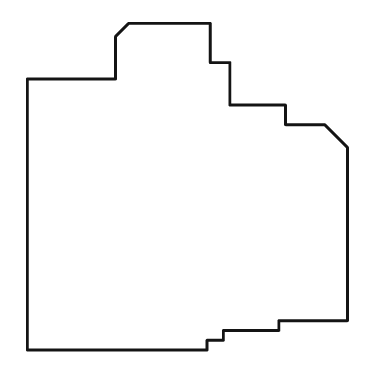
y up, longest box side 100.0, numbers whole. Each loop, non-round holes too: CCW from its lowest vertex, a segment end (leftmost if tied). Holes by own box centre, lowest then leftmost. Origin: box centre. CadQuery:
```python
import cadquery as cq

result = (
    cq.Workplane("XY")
    .moveTo(-49.0, -50.0)
    .lineTo(6.0, -50.0)
    .lineTo(6.0, -47.0)
    .lineTo(11.0, -47.0)
    .lineTo(11.0, -44.0)
    .lineTo(28.0, -44.0)
    .lineTo(28.0, -41.0)
    .lineTo(49.0, -41.0)
    .lineTo(49.0, 12.0)
    .lineTo(42.0, 19.0)
    .lineTo(30.0, 19.0)
    .lineTo(30.0, 25.0)
    .lineTo(13.0, 25.0)
    .lineTo(13.0, 38.0)
    .lineTo(7.0, 38.0)
    .lineTo(7.0, 50.0)
    .lineTo(-18.0, 50.0)
    .lineTo(-22.0, 46.0)
    .lineTo(-22.0, 33.0)
    .lineTo(-49.0, 33.0)
    .close()
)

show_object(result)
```